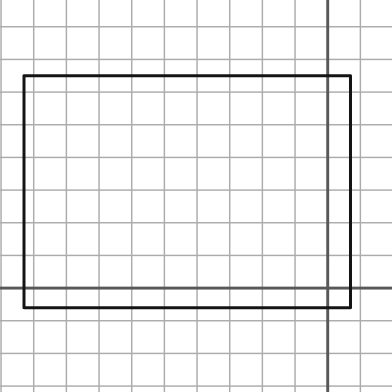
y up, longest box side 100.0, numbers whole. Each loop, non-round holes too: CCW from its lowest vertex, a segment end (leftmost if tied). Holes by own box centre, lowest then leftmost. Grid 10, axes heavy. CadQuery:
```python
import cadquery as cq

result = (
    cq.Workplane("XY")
    .moveTo(-93.0, -6.0)
    .lineTo(7.0, -6.0)
    .lineTo(7.0, 65.0)
    .lineTo(-93.0, 65.0)
    .close()
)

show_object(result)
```